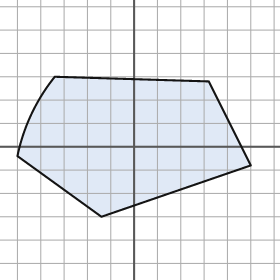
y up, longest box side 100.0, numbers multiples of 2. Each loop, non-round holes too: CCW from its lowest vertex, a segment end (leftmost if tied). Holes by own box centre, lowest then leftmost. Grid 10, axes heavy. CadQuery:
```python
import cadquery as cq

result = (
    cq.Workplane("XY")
    .moveTo(-14.0, -30.0)
    .lineTo(50.0, -8.0)
    .lineTo(32.0, 28.0)
    .lineTo(-34.0, 30.0)
    .threePointArc((-44.0, 14.0), (-50.0, -4.0))
    .close()
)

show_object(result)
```